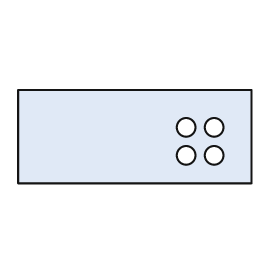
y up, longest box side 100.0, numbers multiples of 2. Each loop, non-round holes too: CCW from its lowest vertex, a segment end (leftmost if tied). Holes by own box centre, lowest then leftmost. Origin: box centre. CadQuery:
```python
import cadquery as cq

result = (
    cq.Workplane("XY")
    .moveTo(-50.0, -20.0)
    .lineTo(50.0, -20.0)
    .lineTo(50.0, 20.0)
    .lineTo(-50.0, 20.0)
    .close()
    .moveTo(22.0, -8.0)
    .circle(4.0)
    .moveTo(34.0, -8.0)
    .circle(4.0)
    .moveTo(22.0, 4.0)
    .circle(4.0)
    .moveTo(34.0, 4.0)
    .circle(4.0)
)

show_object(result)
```